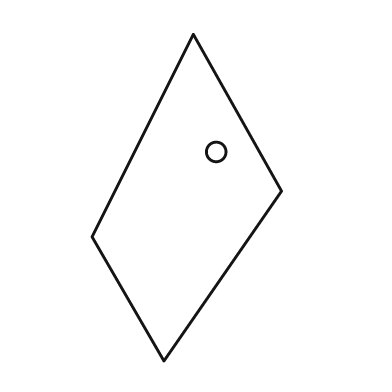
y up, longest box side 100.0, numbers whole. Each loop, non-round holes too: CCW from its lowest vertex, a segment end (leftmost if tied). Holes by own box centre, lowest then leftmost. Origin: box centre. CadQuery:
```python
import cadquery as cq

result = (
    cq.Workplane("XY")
    .moveTo(-7.0, -50.0)
    .lineTo(29.0, 2.0)
    .lineTo(2.0, 50.0)
    .lineTo(-29.0, -12.0)
    .close()
    .moveTo(9.0, 14.0)
    .circle(3.0)
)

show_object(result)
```